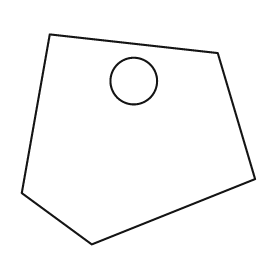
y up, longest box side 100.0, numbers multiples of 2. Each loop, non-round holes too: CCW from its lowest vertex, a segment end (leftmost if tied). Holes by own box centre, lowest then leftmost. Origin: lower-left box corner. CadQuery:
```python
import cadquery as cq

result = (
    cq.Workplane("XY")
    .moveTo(30.0, 0.0)
    .lineTo(100.0, 28.0)
    .lineTo(84.0, 82.0)
    .lineTo(12.0, 90.0)
    .lineTo(0.0, 22.0)
    .close()
    .moveTo(48.0, 70.0)
    .circle(10.0)
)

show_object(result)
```